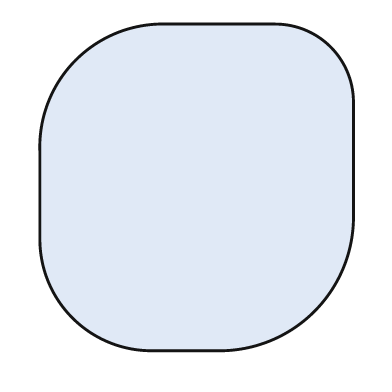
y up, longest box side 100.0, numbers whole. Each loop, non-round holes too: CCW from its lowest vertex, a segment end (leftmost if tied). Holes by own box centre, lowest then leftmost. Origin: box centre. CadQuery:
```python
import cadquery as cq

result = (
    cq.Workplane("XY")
    .moveTo(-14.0, -50.0)
    .lineTo(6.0, -50.0)
    .threePointArc((36.0, -38.0), (48.0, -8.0))
    .lineTo(48.0, 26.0)
    .threePointArc((41.0, 43.0), (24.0, 50.0))
    .lineTo(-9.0, 50.0)
    .threePointArc((-37.0, 39.0), (-48.0, 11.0))
    .lineTo(-48.0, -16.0)
    .threePointArc((-38.0, -40.0), (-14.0, -50.0))
    .close()
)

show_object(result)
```